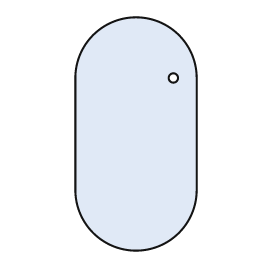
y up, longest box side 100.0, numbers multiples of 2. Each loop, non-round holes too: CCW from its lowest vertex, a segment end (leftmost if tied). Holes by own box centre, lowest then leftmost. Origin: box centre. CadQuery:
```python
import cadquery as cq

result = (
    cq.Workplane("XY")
    .moveTo(-26.0, -24.0)
    .threePointArc((0.0, -50.0), (26.0, -24.0))
    .lineTo(26.0, 24.0)
    .threePointArc((0.0, 50.0), (-26.0, 24.0))
    .close()
    .moveTo(16.0, 24.0)
    .circle(2.0)
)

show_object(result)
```